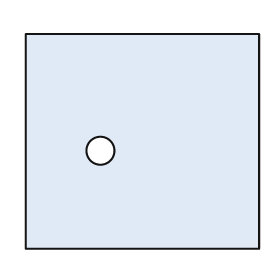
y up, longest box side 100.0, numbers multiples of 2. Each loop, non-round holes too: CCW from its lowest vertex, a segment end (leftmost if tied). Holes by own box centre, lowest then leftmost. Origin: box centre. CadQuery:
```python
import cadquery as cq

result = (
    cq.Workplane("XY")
    .moveTo(-50.0, -46.0)
    .lineTo(50.0, -46.0)
    .lineTo(50.0, 46.0)
    .lineTo(-50.0, 46.0)
    .close()
    .moveTo(-18.0, -4.0)
    .circle(6.0)
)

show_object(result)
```